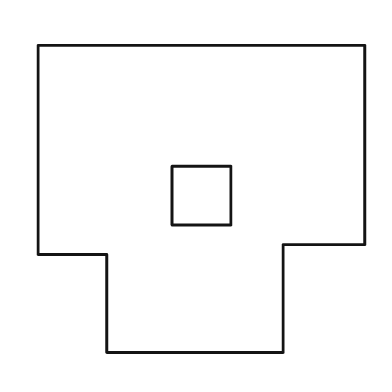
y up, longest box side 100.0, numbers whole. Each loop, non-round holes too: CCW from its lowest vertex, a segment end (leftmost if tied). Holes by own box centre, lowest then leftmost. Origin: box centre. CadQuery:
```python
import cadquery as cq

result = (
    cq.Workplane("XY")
    .moveTo(-29.0, -47.0)
    .lineTo(25.0, -47.0)
    .lineTo(25.0, -14.0)
    .lineTo(50.0, -14.0)
    .lineTo(50.0, 47.0)
    .lineTo(-50.0, 47.0)
    .lineTo(-50.0, -17.0)
    .lineTo(-29.0, -17.0)
    .close()
    .moveTo(-9.0, -8.0)
    .lineTo(9.0, -8.0)
    .lineTo(9.0, 10.0)
    .lineTo(-9.0, 10.0)
    .close()
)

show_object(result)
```